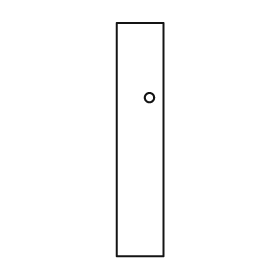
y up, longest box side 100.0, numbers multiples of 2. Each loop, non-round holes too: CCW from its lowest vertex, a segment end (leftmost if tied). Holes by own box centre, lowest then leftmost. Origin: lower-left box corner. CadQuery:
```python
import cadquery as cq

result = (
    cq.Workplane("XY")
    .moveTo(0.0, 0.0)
    .lineTo(20.0, 0.0)
    .lineTo(20.0, 100.0)
    .lineTo(0.0, 100.0)
    .close()
    .moveTo(14.0, 68.0)
    .circle(2.0)
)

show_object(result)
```